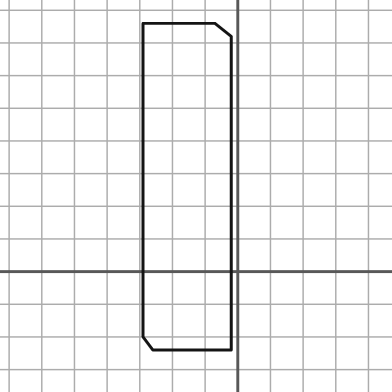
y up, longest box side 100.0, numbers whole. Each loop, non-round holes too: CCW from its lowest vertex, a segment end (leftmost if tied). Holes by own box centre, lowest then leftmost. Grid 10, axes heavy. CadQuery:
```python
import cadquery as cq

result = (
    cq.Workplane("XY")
    .moveTo(-26.0, -24.0)
    .lineTo(-2.0, -24.0)
    .lineTo(-2.0, 72.0)
    .lineTo(-7.0, 76.0)
    .lineTo(-29.0, 76.0)
    .lineTo(-29.0, -20.0)
    .close()
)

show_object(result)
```